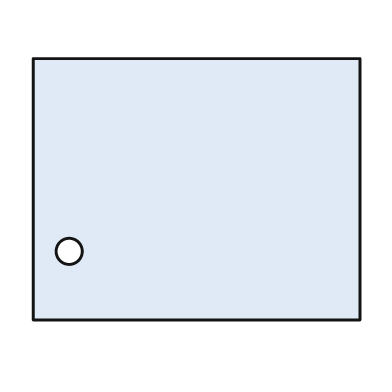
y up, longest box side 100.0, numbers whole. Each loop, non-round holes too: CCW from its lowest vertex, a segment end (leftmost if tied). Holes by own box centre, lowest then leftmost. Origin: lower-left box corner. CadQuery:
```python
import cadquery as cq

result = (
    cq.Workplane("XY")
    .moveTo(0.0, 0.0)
    .lineTo(100.0, 0.0)
    .lineTo(100.0, 80.0)
    .lineTo(0.0, 80.0)
    .close()
    .moveTo(11.0, 21.0)
    .circle(4.0)
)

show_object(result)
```